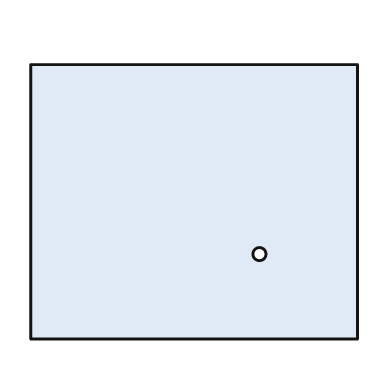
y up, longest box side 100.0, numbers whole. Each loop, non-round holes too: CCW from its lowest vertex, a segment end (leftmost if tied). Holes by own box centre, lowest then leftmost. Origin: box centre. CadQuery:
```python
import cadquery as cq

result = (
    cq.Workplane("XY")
    .moveTo(-50.0, -42.0)
    .lineTo(50.0, -42.0)
    .lineTo(50.0, 42.0)
    .lineTo(-50.0, 42.0)
    .close()
    .moveTo(20.0, -16.0)
    .circle(2.0)
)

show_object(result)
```